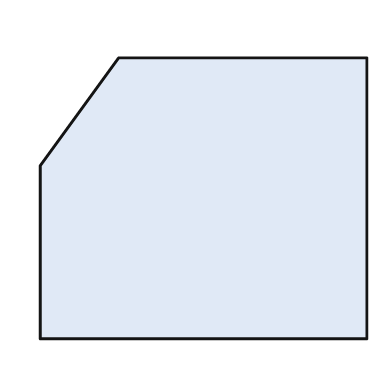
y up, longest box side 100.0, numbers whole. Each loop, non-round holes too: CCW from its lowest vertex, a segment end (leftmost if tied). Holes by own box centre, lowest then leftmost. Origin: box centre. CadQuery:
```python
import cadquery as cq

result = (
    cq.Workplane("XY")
    .moveTo(-50.0, -43.0)
    .lineTo(50.0, -43.0)
    .lineTo(50.0, 43.0)
    .lineTo(-26.0, 43.0)
    .lineTo(-50.0, 10.0)
    .close()
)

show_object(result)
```